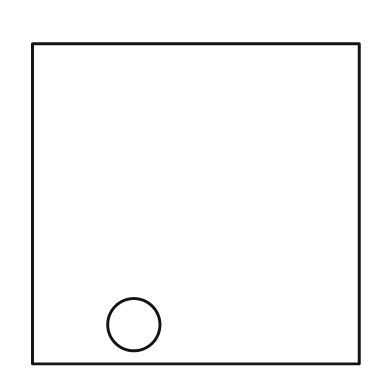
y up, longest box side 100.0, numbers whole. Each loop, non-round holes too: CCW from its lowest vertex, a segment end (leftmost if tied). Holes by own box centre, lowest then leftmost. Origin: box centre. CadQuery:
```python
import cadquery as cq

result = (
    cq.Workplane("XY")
    .moveTo(-50.0, -49.0)
    .lineTo(50.0, -49.0)
    .lineTo(50.0, 49.0)
    .lineTo(-50.0, 49.0)
    .close()
    .moveTo(-19.0, -37.0)
    .circle(8.0)
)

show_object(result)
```